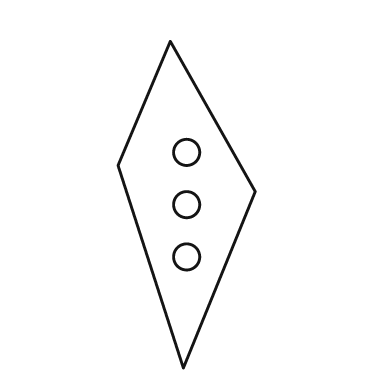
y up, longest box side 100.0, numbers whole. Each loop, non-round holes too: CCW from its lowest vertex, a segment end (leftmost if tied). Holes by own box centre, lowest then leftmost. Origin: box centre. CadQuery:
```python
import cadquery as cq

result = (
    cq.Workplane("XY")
    .moveTo(-1.0, -50.0)
    .lineTo(21.0, 4.0)
    .lineTo(-5.0, 50.0)
    .lineTo(-21.0, 12.0)
    .close()
    .moveTo(0.0, -16.0)
    .circle(4.0)
    .moveTo(0.0, 0.0)
    .circle(4.0)
    .moveTo(0.0, 16.0)
    .circle(4.0)
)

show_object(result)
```